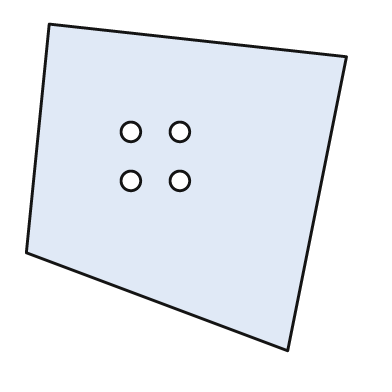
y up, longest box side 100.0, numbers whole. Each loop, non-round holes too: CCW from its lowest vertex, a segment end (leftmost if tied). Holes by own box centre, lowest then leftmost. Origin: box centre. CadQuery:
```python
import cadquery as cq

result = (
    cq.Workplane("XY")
    .moveTo(31.0, -50.0)
    .lineTo(49.0, 40.0)
    .lineTo(-42.0, 50.0)
    .lineTo(-49.0, -20.0)
    .close()
    .moveTo(-17.0, 2.0)
    .circle(3.0)
    .moveTo(-2.0, 2.0)
    .circle(3.0)
    .moveTo(-17.0, 17.0)
    .circle(3.0)
    .moveTo(-2.0, 17.0)
    .circle(3.0)
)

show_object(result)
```